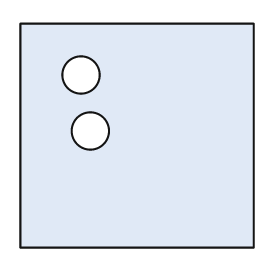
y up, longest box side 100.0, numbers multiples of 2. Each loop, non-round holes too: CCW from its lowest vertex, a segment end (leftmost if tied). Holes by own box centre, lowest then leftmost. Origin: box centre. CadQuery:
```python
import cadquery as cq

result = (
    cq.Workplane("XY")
    .moveTo(-50.0, -48.0)
    .lineTo(50.0, -48.0)
    .lineTo(50.0, 48.0)
    .lineTo(-50.0, 48.0)
    .close()
    .moveTo(-20.0, 2.0)
    .circle(8.0)
    .moveTo(-24.0, 26.0)
    .circle(8.0)
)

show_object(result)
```